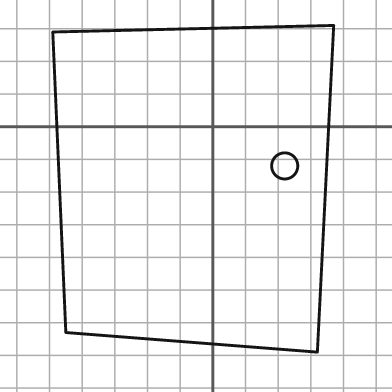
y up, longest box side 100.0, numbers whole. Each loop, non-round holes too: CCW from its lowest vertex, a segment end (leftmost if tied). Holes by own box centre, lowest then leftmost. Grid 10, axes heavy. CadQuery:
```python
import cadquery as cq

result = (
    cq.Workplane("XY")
    .moveTo(32.0, -69.0)
    .lineTo(37.0, 31.0)
    .lineTo(-49.0, 29.0)
    .lineTo(-45.0, -63.0)
    .close()
    .moveTo(22.0, -12.0)
    .circle(4.0)
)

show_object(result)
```